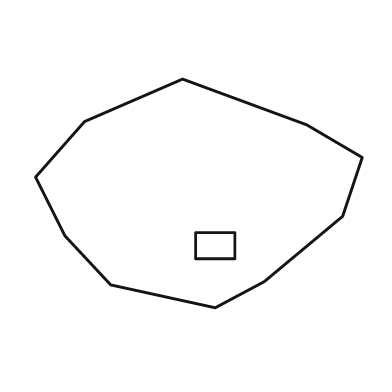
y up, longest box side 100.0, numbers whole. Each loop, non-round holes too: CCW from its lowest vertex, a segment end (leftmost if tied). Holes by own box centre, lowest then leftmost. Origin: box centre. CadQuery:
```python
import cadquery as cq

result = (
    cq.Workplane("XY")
    .moveTo(5.0, -35.0)
    .lineTo(20.0, -27.0)
    .lineTo(44.0, -7.0)
    .lineTo(50.0, 11.0)
    .lineTo(33.0, 21.0)
    .lineTo(-5.0, 35.0)
    .lineTo(-35.0, 22.0)
    .lineTo(-50.0, 5.0)
    .lineTo(-41.0, -13.0)
    .lineTo(-27.0, -28.0)
    .close()
    .moveTo(-1.0, -20.0)
    .lineTo(11.0, -20.0)
    .lineTo(11.0, -12.0)
    .lineTo(-1.0, -12.0)
    .close()
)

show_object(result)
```